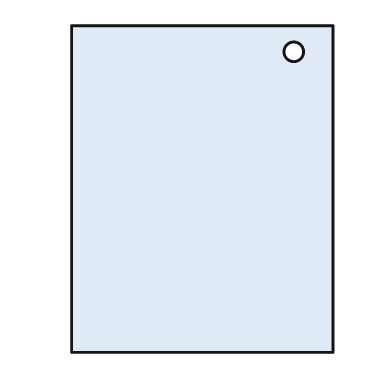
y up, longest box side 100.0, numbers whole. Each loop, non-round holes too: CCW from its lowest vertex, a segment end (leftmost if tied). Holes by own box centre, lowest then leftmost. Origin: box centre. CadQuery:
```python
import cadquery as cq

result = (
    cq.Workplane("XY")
    .moveTo(-40.0, -50.0)
    .lineTo(40.0, -50.0)
    .lineTo(40.0, 50.0)
    .lineTo(-40.0, 50.0)
    .close()
    .moveTo(28.0, 42.0)
    .circle(3.0)
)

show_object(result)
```